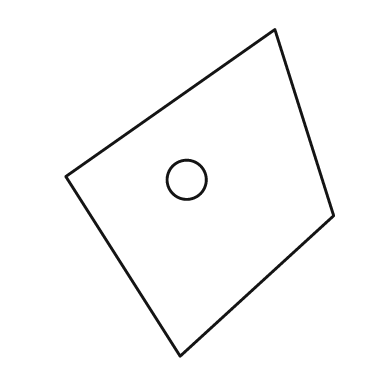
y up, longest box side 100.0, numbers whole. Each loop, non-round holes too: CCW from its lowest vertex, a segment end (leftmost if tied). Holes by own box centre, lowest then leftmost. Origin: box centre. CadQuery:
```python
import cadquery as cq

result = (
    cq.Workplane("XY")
    .moveTo(-6.0, -50.0)
    .lineTo(41.0, -7.0)
    .lineTo(23.0, 50.0)
    .lineTo(-41.0, 5.0)
    .close()
    .moveTo(-4.0, 4.0)
    .circle(6.0)
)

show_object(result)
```